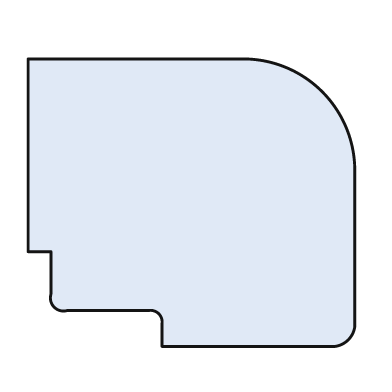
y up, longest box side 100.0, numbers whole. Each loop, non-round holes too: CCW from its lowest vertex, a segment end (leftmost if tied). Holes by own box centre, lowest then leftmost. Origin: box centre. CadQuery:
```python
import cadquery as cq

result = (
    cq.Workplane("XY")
    .moveTo(-9.0, -44.0)
    .lineTo(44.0, -44.0)
    .threePointArc((48.0, -42.0), (50.0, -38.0))
    .lineTo(50.0, 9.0)
    .threePointArc((40.0, 34.0), (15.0, 44.0))
    .lineTo(-50.0, 44.0)
    .lineTo(-50.0, -15.0)
    .lineTo(-43.0, -15.0)
    .lineTo(-43.0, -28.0)
    .threePointArc((-42.0, -32.0), (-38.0, -33.0))
    .lineTo(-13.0, -33.0)
    .threePointArc((-10.0, -34.0), (-9.0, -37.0))
    .close()
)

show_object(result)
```